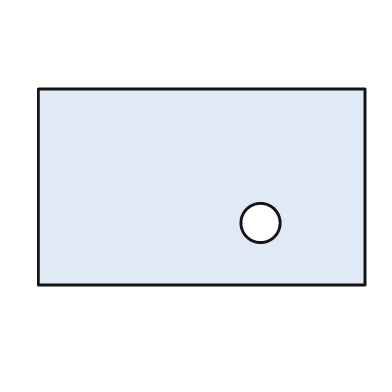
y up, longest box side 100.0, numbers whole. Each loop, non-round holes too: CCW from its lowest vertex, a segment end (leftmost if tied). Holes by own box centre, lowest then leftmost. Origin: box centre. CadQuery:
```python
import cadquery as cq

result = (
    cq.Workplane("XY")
    .moveTo(-50.0, -30.0)
    .lineTo(50.0, -30.0)
    .lineTo(50.0, 30.0)
    .lineTo(-50.0, 30.0)
    .close()
    .moveTo(18.0, -11.0)
    .circle(6.0)
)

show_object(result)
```